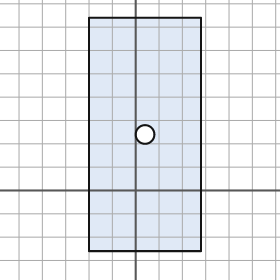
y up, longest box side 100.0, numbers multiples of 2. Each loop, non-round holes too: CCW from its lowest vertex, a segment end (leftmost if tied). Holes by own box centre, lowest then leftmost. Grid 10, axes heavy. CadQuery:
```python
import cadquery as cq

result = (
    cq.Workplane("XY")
    .moveTo(-20.0, -26.0)
    .lineTo(28.0, -26.0)
    .lineTo(28.0, 74.0)
    .lineTo(-20.0, 74.0)
    .close()
    .moveTo(4.0, 24.0)
    .circle(4.0)
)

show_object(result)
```